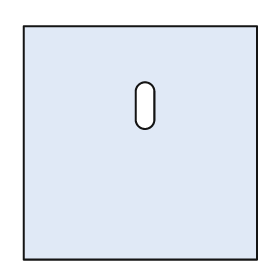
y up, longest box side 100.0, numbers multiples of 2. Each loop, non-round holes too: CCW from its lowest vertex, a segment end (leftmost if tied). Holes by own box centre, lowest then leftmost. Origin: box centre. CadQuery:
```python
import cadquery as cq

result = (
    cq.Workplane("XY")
    .moveTo(-50.0, -50.0)
    .lineTo(50.0, -50.0)
    .lineTo(50.0, 50.0)
    .lineTo(-50.0, 50.0)
    .close()
    .moveTo(-2.0, 10.0)
    .threePointArc((2.0, 6.0), (6.0, 10.0))
    .lineTo(6.0, 22.0)
    .threePointArc((2.0, 26.0), (-2.0, 22.0))
    .close()
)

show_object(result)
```